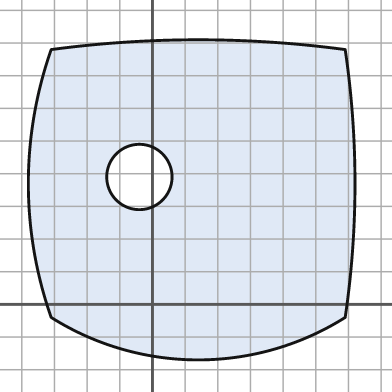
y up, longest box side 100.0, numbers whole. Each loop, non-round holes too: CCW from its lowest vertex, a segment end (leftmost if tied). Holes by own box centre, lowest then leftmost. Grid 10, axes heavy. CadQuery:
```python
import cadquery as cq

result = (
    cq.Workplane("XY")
    .moveTo(-31.0, -4.0)
    .threePointArc((14.0, -17.0), (59.0, -4.0))
    .threePointArc((62.0, 37.0), (59.0, 78.0))
    .threePointArc((14.0, 81.0), (-31.0, 78.0))
    .threePointArc((-38.0, 37.0), (-31.0, -4.0))
    .close()
    .moveTo(-4.0, 39.0)
    .circle(10.0)
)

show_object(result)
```